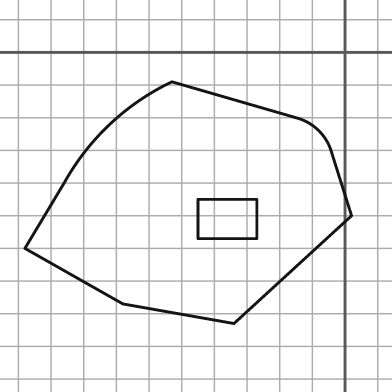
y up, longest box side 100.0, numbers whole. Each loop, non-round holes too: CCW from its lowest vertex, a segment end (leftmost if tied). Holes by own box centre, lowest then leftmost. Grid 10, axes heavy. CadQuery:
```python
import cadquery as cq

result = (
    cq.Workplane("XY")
    .moveTo(-34.0, -83.0)
    .lineTo(2.0, -50.0)
    .lineTo(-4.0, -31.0)
    .threePointArc((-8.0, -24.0), (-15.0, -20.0))
    .lineTo(-53.0, -9.0)
    .threePointArc((-72.0, -22.0), (-86.0, -40.0))
    .lineTo(-98.0, -60.0)
    .lineTo(-68.0, -77.0)
    .close()
    .moveTo(-45.0, -57.0)
    .lineTo(-27.0, -57.0)
    .lineTo(-27.0, -45.0)
    .lineTo(-45.0, -45.0)
    .close()
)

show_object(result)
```